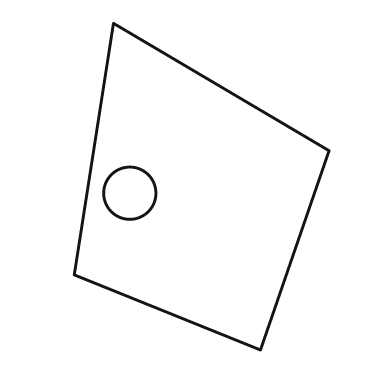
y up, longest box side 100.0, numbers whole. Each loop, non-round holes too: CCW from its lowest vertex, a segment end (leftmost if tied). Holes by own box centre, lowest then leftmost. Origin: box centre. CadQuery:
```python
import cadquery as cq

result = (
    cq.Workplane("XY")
    .moveTo(18.0, -50.0)
    .lineTo(39.0, 11.0)
    .lineTo(-27.0, 50.0)
    .lineTo(-39.0, -27.0)
    .close()
    .moveTo(-22.0, -2.0)
    .circle(8.0)
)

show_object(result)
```